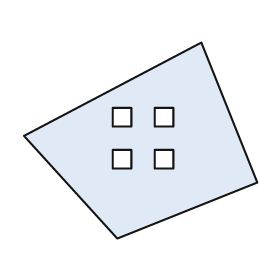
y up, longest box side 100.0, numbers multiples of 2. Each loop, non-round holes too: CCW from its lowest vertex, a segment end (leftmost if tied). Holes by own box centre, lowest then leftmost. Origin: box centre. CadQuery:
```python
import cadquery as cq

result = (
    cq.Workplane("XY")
    .moveTo(-10.0, -42.0)
    .lineTo(50.0, -18.0)
    .lineTo(26.0, 42.0)
    .lineTo(-50.0, 2.0)
    .close()
    .moveTo(-12.0, -12.0)
    .lineTo(-4.0, -12.0)
    .lineTo(-4.0, -4.0)
    .lineTo(-12.0, -4.0)
    .close()
    .moveTo(6.0, -12.0)
    .lineTo(14.0, -12.0)
    .lineTo(14.0, -4.0)
    .lineTo(6.0, -4.0)
    .close()
    .moveTo(-12.0, 6.0)
    .lineTo(-4.0, 6.0)
    .lineTo(-4.0, 14.0)
    .lineTo(-12.0, 14.0)
    .close()
    .moveTo(6.0, 6.0)
    .lineTo(14.0, 6.0)
    .lineTo(14.0, 14.0)
    .lineTo(6.0, 14.0)
    .close()
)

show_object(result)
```